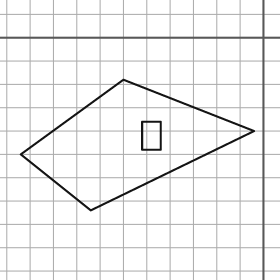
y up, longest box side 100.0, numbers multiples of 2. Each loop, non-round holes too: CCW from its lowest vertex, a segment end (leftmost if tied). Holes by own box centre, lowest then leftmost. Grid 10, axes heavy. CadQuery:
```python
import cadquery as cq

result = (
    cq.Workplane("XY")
    .moveTo(-74.0, -74.0)
    .lineTo(-4.0, -40.0)
    .lineTo(-60.0, -18.0)
    .lineTo(-104.0, -50.0)
    .close()
    .moveTo(-52.0, -48.0)
    .lineTo(-44.0, -48.0)
    .lineTo(-44.0, -36.0)
    .lineTo(-52.0, -36.0)
    .close()
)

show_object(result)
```